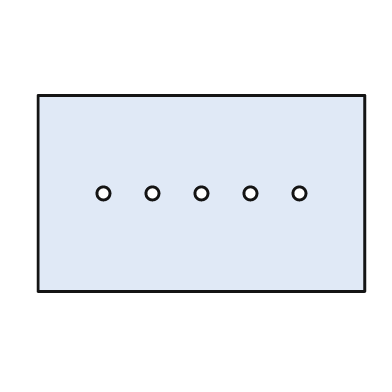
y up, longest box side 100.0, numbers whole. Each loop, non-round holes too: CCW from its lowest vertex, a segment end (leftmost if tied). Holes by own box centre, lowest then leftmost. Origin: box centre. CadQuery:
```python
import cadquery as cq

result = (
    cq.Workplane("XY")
    .moveTo(-50.0, -30.0)
    .lineTo(50.0, -30.0)
    .lineTo(50.0, 30.0)
    .lineTo(-50.0, 30.0)
    .close()
    .moveTo(-30.0, 0.0)
    .circle(2.0)
    .moveTo(-15.0, 0.0)
    .circle(2.0)
    .moveTo(0.0, 0.0)
    .circle(2.0)
    .moveTo(15.0, 0.0)
    .circle(2.0)
    .moveTo(30.0, 0.0)
    .circle(2.0)
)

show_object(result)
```